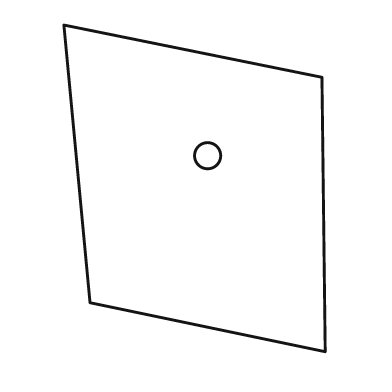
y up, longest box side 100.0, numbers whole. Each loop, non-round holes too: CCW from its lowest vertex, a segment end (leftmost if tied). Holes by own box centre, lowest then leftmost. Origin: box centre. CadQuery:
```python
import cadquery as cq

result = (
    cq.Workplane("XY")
    .moveTo(40.0, -50.0)
    .lineTo(39.0, 34.0)
    .lineTo(-40.0, 50.0)
    .lineTo(-32.0, -35.0)
    .close()
    .moveTo(4.0, 10.0)
    .circle(4.0)
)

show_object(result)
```